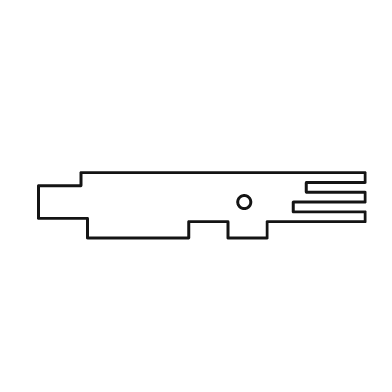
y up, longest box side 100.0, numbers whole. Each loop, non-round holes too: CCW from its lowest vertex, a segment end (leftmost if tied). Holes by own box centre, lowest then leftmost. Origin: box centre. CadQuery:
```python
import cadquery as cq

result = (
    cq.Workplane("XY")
    .moveTo(-35.0, -10.0)
    .lineTo(-4.0, -10.0)
    .lineTo(-4.0, -5.0)
    .lineTo(8.0, -5.0)
    .lineTo(8.0, -10.0)
    .lineTo(20.0, -10.0)
    .lineTo(20.0, -5.0)
    .lineTo(50.0, -5.0)
    .lineTo(50.0, -2.0)
    .lineTo(28.0, -2.0)
    .lineTo(28.0, 1.0)
    .lineTo(50.0, 1.0)
    .lineTo(50.0, 4.0)
    .lineTo(32.0, 4.0)
    .lineTo(32.0, 7.0)
    .lineTo(50.0, 7.0)
    .lineTo(50.0, 10.0)
    .lineTo(-37.0, 10.0)
    .lineTo(-37.0, 6.0)
    .lineTo(-50.0, 6.0)
    .lineTo(-50.0, -4.0)
    .lineTo(-35.0, -4.0)
    .close()
    .moveTo(13.0, 1.0)
    .circle(2.0)
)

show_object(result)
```